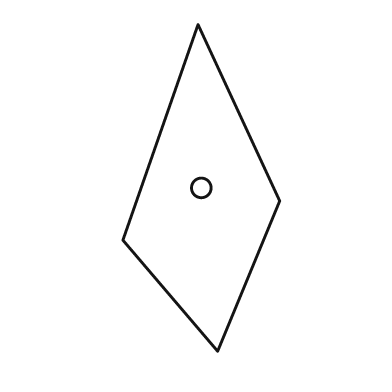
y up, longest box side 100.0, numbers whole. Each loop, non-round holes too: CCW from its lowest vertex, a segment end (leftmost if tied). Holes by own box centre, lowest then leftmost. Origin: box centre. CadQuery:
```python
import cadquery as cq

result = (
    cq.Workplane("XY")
    .moveTo(5.0, -50.0)
    .lineTo(24.0, -4.0)
    .lineTo(-1.0, 50.0)
    .lineTo(-24.0, -16.0)
    .close()
    .moveTo(0.0, 0.0)
    .circle(3.0)
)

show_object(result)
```